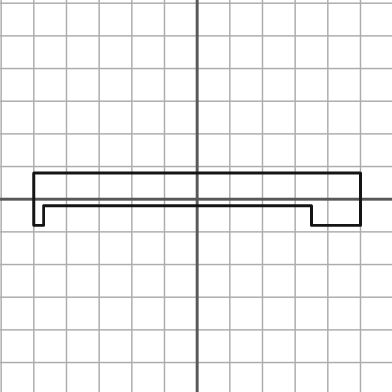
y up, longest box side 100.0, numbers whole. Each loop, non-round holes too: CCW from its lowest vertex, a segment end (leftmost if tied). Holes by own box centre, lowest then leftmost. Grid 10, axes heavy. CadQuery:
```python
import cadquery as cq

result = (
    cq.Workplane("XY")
    .moveTo(-50.0, -8.0)
    .lineTo(-47.0, -8.0)
    .lineTo(-47.0, -2.0)
    .lineTo(35.0, -2.0)
    .lineTo(35.0, -8.0)
    .lineTo(50.0, -8.0)
    .lineTo(50.0, 8.0)
    .lineTo(-50.0, 8.0)
    .close()
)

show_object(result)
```